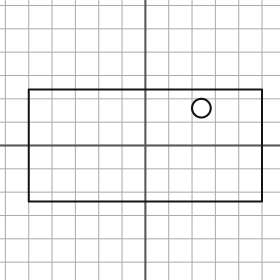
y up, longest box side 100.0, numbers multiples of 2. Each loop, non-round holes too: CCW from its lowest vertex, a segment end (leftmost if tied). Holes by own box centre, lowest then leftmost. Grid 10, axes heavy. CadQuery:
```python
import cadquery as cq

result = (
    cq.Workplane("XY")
    .moveTo(-50.0, -24.0)
    .lineTo(50.0, -24.0)
    .lineTo(50.0, 24.0)
    .lineTo(-50.0, 24.0)
    .close()
    .moveTo(24.0, 16.0)
    .circle(4.0)
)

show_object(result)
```